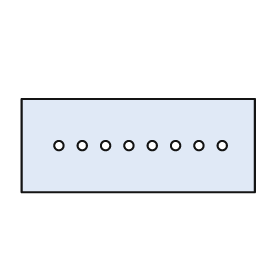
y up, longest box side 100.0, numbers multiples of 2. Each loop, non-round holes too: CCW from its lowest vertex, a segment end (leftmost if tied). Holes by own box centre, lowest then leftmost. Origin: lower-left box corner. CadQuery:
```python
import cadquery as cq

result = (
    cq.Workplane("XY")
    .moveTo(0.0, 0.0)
    .lineTo(100.0, 0.0)
    .lineTo(100.0, 40.0)
    .lineTo(0.0, 40.0)
    .close()
    .moveTo(16.0, 20.0)
    .circle(2.0)
    .moveTo(26.0, 20.0)
    .circle(2.0)
    .moveTo(36.0, 20.0)
    .circle(2.0)
    .moveTo(46.0, 20.0)
    .circle(2.0)
    .moveTo(56.0, 20.0)
    .circle(2.0)
    .moveTo(66.0, 20.0)
    .circle(2.0)
    .moveTo(76.0, 20.0)
    .circle(2.0)
    .moveTo(86.0, 20.0)
    .circle(2.0)
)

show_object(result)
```